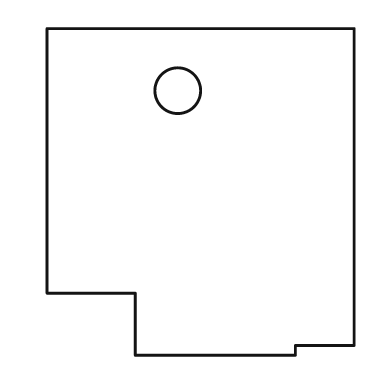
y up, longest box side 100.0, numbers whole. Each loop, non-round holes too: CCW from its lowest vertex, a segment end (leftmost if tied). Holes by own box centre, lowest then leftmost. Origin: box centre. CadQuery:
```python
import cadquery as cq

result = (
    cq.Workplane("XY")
    .moveTo(-20.0, -50.0)
    .lineTo(29.0, -50.0)
    .lineTo(29.0, -47.0)
    .lineTo(47.0, -47.0)
    .lineTo(47.0, 50.0)
    .lineTo(-47.0, 50.0)
    .lineTo(-47.0, -31.0)
    .lineTo(-20.0, -31.0)
    .close()
    .moveTo(-7.0, 31.0)
    .circle(7.0)
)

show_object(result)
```